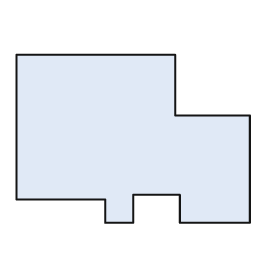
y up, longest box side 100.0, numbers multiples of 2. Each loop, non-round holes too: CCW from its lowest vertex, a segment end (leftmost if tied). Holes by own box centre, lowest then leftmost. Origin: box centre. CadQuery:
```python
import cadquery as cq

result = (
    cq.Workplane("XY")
    .moveTo(-12.0, -36.0)
    .lineTo(0.0, -36.0)
    .lineTo(0.0, -24.0)
    .lineTo(20.0, -24.0)
    .lineTo(20.0, -36.0)
    .lineTo(50.0, -36.0)
    .lineTo(50.0, 10.0)
    .lineTo(18.0, 10.0)
    .lineTo(18.0, 36.0)
    .lineTo(-50.0, 36.0)
    .lineTo(-50.0, -26.0)
    .lineTo(-12.0, -26.0)
    .close()
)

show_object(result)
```